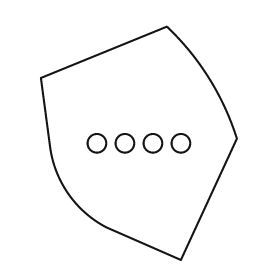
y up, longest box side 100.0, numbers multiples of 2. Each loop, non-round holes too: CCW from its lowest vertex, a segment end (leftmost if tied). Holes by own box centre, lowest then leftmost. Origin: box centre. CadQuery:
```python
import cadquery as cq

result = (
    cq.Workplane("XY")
    .moveTo(18.0, -50.0)
    .lineTo(42.0, 2.0)
    .threePointArc((30.0, 28.0), (12.0, 50.0))
    .lineTo(-42.0, 28.0)
    .lineTo(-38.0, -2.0)
    .threePointArc((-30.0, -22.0), (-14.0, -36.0))
    .close()
    .moveTo(-18.0, 0.0)
    .circle(4.0)
    .moveTo(-6.0, 0.0)
    .circle(4.0)
    .moveTo(6.0, 0.0)
    .circle(4.0)
    .moveTo(18.0, 0.0)
    .circle(4.0)
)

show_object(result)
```